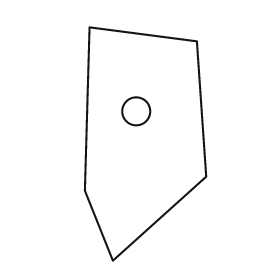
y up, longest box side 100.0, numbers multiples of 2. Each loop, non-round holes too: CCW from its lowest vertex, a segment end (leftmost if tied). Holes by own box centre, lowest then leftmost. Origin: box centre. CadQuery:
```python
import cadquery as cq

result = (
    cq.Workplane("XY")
    .moveTo(-14.0, -50.0)
    .lineTo(26.0, -14.0)
    .lineTo(22.0, 44.0)
    .lineTo(-24.0, 50.0)
    .lineTo(-26.0, -20.0)
    .close()
    .moveTo(-4.0, 14.0)
    .circle(6.0)
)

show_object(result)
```